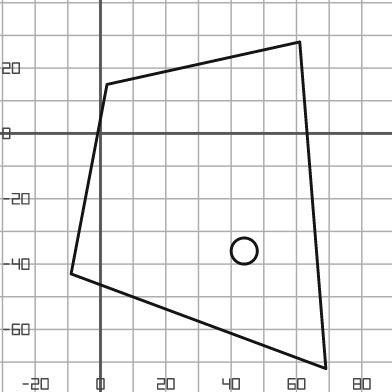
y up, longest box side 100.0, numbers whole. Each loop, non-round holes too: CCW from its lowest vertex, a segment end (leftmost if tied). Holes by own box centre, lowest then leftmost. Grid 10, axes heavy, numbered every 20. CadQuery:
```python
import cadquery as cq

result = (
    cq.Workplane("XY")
    .moveTo(69.0, -72.0)
    .lineTo(61.0, 28.0)
    .lineTo(2.0, 15.0)
    .lineTo(-9.0, -43.0)
    .close()
    .moveTo(44.0, -36.0)
    .circle(4.0)
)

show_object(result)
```